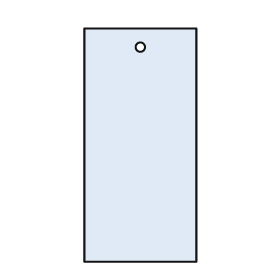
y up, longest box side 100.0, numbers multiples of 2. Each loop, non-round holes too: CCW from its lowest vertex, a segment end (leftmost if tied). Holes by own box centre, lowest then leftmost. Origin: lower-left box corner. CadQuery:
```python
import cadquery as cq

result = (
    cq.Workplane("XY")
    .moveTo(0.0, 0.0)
    .lineTo(48.0, 0.0)
    .lineTo(48.0, 100.0)
    .lineTo(0.0, 100.0)
    .close()
    .moveTo(24.0, 92.0)
    .circle(2.0)
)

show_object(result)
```